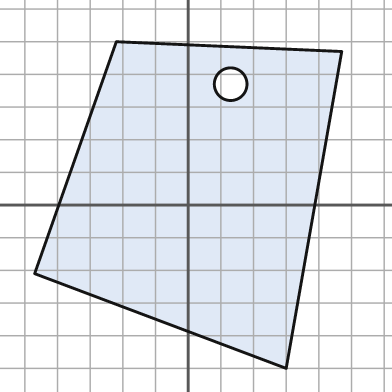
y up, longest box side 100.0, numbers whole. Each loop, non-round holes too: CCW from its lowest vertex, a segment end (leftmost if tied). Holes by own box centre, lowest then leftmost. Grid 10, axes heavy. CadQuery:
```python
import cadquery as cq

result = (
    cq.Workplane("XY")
    .moveTo(30.0, -50.0)
    .lineTo(47.0, 47.0)
    .lineTo(-22.0, 50.0)
    .lineTo(-47.0, -21.0)
    .close()
    .moveTo(13.0, 37.0)
    .circle(5.0)
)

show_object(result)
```